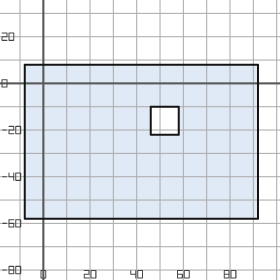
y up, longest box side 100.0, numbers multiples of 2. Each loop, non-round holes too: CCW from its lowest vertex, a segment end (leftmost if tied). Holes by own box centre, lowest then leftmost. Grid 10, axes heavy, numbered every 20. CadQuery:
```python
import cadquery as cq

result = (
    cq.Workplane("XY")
    .moveTo(-8.0, -58.0)
    .lineTo(92.0, -58.0)
    .lineTo(92.0, 8.0)
    .lineTo(-8.0, 8.0)
    .close()
    .moveTo(46.0, -22.0)
    .lineTo(58.0, -22.0)
    .lineTo(58.0, -10.0)
    .lineTo(46.0, -10.0)
    .close()
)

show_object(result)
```